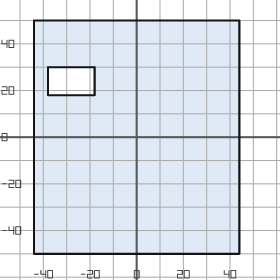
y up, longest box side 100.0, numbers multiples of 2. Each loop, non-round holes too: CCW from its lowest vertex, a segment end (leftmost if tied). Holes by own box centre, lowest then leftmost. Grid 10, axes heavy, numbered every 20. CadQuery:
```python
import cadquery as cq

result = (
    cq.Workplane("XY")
    .moveTo(-44.0, -50.0)
    .lineTo(44.0, -50.0)
    .lineTo(44.0, 50.0)
    .lineTo(-44.0, 50.0)
    .close()
    .moveTo(-38.0, 18.0)
    .lineTo(-18.0, 18.0)
    .lineTo(-18.0, 30.0)
    .lineTo(-38.0, 30.0)
    .close()
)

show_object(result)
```